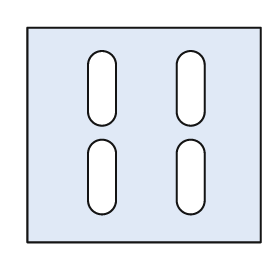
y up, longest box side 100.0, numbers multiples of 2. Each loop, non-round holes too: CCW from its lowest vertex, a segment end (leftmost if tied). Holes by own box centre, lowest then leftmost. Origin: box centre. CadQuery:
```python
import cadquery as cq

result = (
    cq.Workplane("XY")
    .moveTo(-50.0, -46.0)
    .lineTo(50.0, -46.0)
    .lineTo(50.0, 46.0)
    .lineTo(-50.0, 46.0)
    .close()
    .moveTo(-24.0, -28.0)
    .threePointArc((-18.0, -34.0), (-12.0, -28.0))
    .lineTo(-12.0, -8.0)
    .threePointArc((-18.0, -2.0), (-24.0, -8.0))
    .close()
    .moveTo(14.0, -28.0)
    .threePointArc((20.0, -34.0), (26.0, -28.0))
    .lineTo(26.0, -8.0)
    .threePointArc((20.0, -2.0), (14.0, -8.0))
    .close()
    .moveTo(-24.0, 10.0)
    .threePointArc((-18.0, 4.0), (-12.0, 10.0))
    .lineTo(-12.0, 30.0)
    .threePointArc((-18.0, 36.0), (-24.0, 30.0))
    .close()
    .moveTo(14.0, 10.0)
    .threePointArc((20.0, 4.0), (26.0, 10.0))
    .lineTo(26.0, 30.0)
    .threePointArc((20.0, 36.0), (14.0, 30.0))
    .close()
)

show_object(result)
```